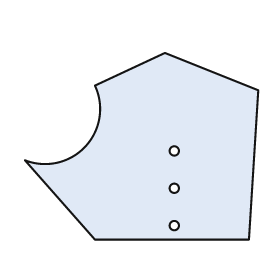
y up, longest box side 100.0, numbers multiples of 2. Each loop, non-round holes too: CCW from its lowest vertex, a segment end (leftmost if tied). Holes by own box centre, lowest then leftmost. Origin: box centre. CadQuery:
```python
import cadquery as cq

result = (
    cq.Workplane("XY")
    .moveTo(-20.0, -40.0)
    .lineTo(46.0, -40.0)
    .lineTo(50.0, 24.0)
    .lineTo(10.0, 40.0)
    .lineTo(-20.0, 26.0)
    .threePointArc((-24.0, 0.0), (-50.0, -6.0))
    .close()
    .moveTo(14.0, -34.0)
    .circle(2.0)
    .moveTo(14.0, -18.0)
    .circle(2.0)
    .moveTo(14.0, -2.0)
    .circle(2.0)
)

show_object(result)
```